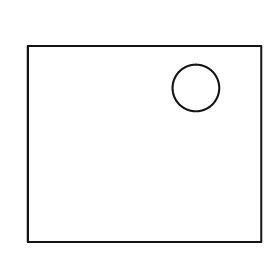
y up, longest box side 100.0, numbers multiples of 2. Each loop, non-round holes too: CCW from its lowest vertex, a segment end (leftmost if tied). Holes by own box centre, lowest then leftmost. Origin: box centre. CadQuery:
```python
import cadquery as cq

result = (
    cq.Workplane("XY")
    .moveTo(-50.0, -42.0)
    .lineTo(50.0, -42.0)
    .lineTo(50.0, 42.0)
    .lineTo(-50.0, 42.0)
    .close()
    .moveTo(22.0, 24.0)
    .circle(10.0)
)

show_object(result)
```